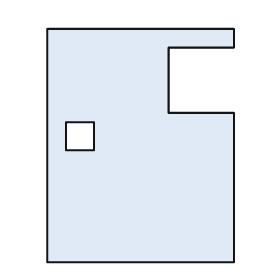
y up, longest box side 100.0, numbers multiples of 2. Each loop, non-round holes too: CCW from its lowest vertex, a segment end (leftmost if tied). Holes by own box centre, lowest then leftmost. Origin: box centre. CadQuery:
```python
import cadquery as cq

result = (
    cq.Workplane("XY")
    .moveTo(-40.0, -50.0)
    .lineTo(40.0, -50.0)
    .lineTo(40.0, 14.0)
    .lineTo(12.0, 14.0)
    .lineTo(12.0, 42.0)
    .lineTo(40.0, 42.0)
    .lineTo(40.0, 50.0)
    .lineTo(-40.0, 50.0)
    .close()
    .moveTo(-32.0, -2.0)
    .lineTo(-20.0, -2.0)
    .lineTo(-20.0, 10.0)
    .lineTo(-32.0, 10.0)
    .close()
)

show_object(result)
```